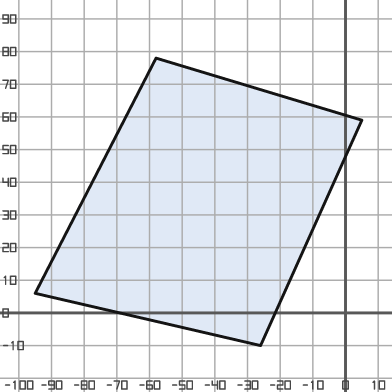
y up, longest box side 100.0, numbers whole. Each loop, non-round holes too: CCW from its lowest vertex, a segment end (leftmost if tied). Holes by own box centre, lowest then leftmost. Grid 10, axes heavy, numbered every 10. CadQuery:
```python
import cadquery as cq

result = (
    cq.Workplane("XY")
    .moveTo(-26.0, -10.0)
    .lineTo(5.0, 59.0)
    .lineTo(-58.0, 78.0)
    .lineTo(-95.0, 6.0)
    .close()
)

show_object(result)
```